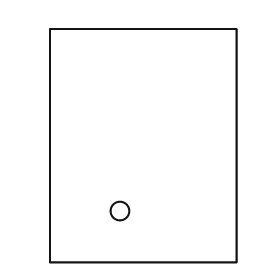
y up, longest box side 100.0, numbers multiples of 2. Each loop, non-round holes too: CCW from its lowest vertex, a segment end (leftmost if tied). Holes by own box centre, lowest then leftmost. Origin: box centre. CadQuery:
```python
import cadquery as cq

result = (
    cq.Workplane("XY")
    .moveTo(-40.0, -50.0)
    .lineTo(40.0, -50.0)
    .lineTo(40.0, 50.0)
    .lineTo(-40.0, 50.0)
    .close()
    .moveTo(-10.0, -28.0)
    .circle(4.0)
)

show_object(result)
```